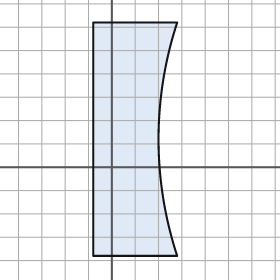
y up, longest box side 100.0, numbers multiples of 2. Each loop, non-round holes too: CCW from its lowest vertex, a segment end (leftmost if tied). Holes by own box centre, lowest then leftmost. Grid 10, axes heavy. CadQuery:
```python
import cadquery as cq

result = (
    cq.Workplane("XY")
    .moveTo(-8.0, -38.0)
    .lineTo(28.0, -38.0)
    .threePointArc((20.0, 12.0), (28.0, 62.0))
    .lineTo(-8.0, 62.0)
    .close()
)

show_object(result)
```